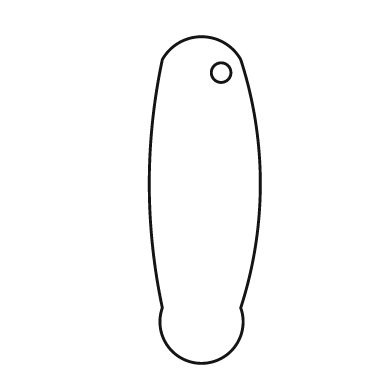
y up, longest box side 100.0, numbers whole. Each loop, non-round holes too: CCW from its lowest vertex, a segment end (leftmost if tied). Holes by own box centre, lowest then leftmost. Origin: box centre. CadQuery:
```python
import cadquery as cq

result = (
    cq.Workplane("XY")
    .moveTo(-13.0, -33.0)
    .threePointArc((-1.0, -50.0), (11.0, -33.0))
    .threePointArc((17.0, 5.0), (11.0, 43.0))
    .threePointArc((-1.0, 50.0), (-13.0, 43.0))
    .threePointArc((-17.0, 5.0), (-13.0, -33.0))
    .close()
    .moveTo(5.0, 39.0)
    .circle(3.0)
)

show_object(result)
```